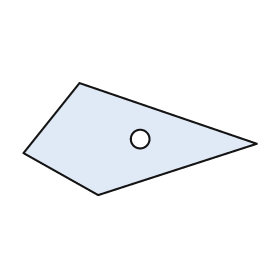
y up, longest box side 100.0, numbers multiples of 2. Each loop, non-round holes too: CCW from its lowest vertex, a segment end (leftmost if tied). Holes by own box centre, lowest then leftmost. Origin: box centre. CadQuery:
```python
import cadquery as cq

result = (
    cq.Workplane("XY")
    .moveTo(-18.0, -24.0)
    .lineTo(50.0, -2.0)
    .lineTo(-26.0, 24.0)
    .lineTo(-50.0, -6.0)
    .close()
    .moveTo(0.0, 0.0)
    .circle(4.0)
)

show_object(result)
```